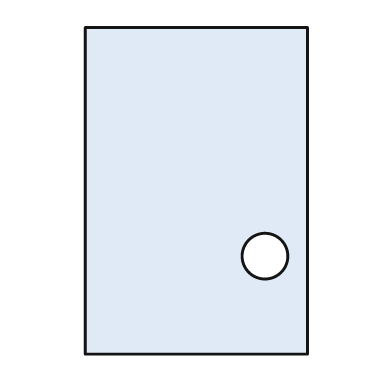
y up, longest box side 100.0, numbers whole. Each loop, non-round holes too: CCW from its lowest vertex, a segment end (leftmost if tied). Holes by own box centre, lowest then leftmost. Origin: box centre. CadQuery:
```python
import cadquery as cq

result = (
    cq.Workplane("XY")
    .moveTo(-34.0, -50.0)
    .lineTo(34.0, -50.0)
    .lineTo(34.0, 50.0)
    .lineTo(-34.0, 50.0)
    .close()
    .moveTo(21.0, -20.0)
    .circle(7.0)
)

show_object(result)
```